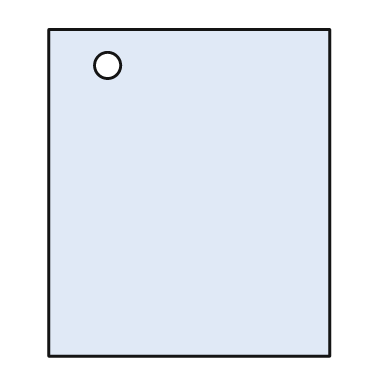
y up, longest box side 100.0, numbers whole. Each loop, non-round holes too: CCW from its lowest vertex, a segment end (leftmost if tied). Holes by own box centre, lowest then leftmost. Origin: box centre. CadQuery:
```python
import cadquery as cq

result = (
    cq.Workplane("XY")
    .moveTo(-43.0, -50.0)
    .lineTo(43.0, -50.0)
    .lineTo(43.0, 50.0)
    .lineTo(-43.0, 50.0)
    .close()
    .moveTo(-25.0, 39.0)
    .circle(4.0)
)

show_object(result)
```